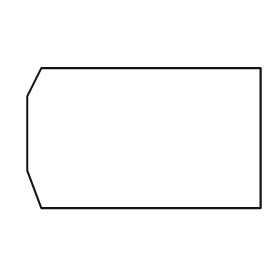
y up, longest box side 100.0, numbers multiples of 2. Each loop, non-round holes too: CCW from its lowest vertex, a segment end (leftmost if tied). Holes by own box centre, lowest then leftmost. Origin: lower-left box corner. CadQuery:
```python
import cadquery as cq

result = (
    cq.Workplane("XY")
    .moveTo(6.0, 0.0)
    .lineTo(100.0, 0.0)
    .lineTo(100.0, 60.0)
    .lineTo(6.0, 60.0)
    .lineTo(0.0, 48.0)
    .lineTo(0.0, 16.0)
    .close()
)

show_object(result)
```